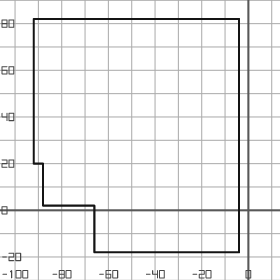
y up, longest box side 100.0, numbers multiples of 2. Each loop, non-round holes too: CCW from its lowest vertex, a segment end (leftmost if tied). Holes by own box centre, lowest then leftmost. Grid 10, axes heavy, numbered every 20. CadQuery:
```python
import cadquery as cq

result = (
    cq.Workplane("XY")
    .moveTo(-66.0, -18.0)
    .lineTo(-4.0, -18.0)
    .lineTo(-4.0, 82.0)
    .lineTo(-92.0, 82.0)
    .lineTo(-92.0, 20.0)
    .lineTo(-88.0, 20.0)
    .lineTo(-88.0, 2.0)
    .lineTo(-66.0, 2.0)
    .close()
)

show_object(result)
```